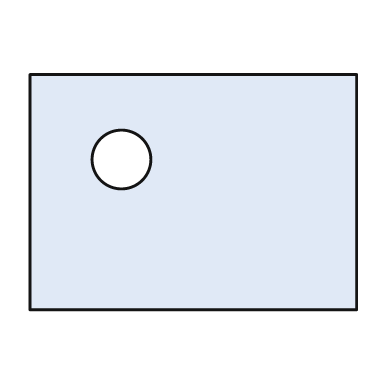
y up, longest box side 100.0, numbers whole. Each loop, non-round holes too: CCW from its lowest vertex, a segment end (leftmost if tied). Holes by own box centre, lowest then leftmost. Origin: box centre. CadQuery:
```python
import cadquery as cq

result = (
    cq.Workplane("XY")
    .moveTo(-50.0, -36.0)
    .lineTo(50.0, -36.0)
    .lineTo(50.0, 36.0)
    .lineTo(-50.0, 36.0)
    .close()
    .moveTo(-22.0, 10.0)
    .circle(9.0)
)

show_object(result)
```